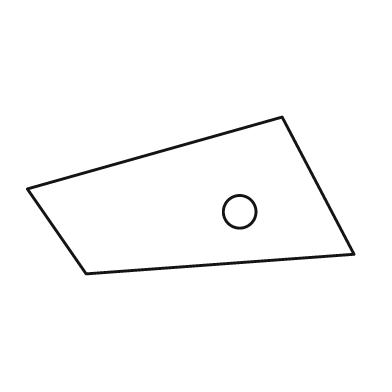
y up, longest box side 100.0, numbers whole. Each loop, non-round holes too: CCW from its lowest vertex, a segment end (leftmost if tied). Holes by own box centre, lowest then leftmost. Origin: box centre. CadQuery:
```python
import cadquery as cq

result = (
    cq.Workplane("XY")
    .moveTo(-32.0, -24.0)
    .lineTo(50.0, -18.0)
    .lineTo(28.0, 24.0)
    .lineTo(-50.0, 2.0)
    .close()
    .moveTo(15.0, -5.0)
    .circle(5.0)
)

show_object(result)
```